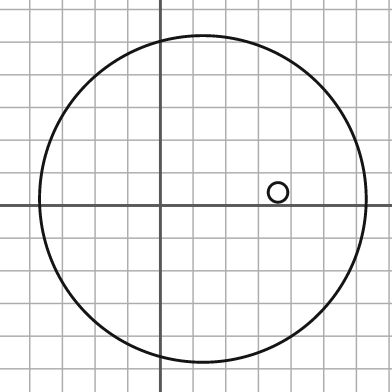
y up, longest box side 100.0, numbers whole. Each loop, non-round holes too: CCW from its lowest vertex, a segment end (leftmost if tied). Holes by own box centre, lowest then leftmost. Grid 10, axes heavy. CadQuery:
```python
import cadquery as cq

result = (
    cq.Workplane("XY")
    .moveTo(13.0, 2.0)
    .circle(50.0)
    .moveTo(36.0, 4.0)
    .circle(3.0)
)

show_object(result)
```